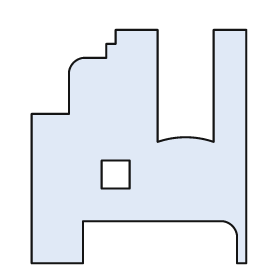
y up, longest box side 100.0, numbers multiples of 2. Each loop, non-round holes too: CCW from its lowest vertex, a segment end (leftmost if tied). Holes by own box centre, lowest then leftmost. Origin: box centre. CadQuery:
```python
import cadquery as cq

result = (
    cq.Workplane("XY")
    .moveTo(-46.0, -50.0)
    .lineTo(-24.0, -50.0)
    .lineTo(-24.0, -32.0)
    .lineTo(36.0, -32.0)
    .threePointArc((40.0, -34.0), (42.0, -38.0))
    .lineTo(42.0, -50.0)
    .lineTo(46.0, -50.0)
    .lineTo(46.0, 50.0)
    .lineTo(32.0, 50.0)
    .lineTo(32.0, 2.0)
    .threePointArc((20.0, 4.0), (8.0, 2.0))
    .lineTo(8.0, 50.0)
    .lineTo(-10.0, 50.0)
    .lineTo(-10.0, 44.0)
    .lineTo(-14.0, 44.0)
    .lineTo(-14.0, 38.0)
    .lineTo(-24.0, 38.0)
    .threePointArc((-28.0, 36.0), (-30.0, 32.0))
    .lineTo(-30.0, 14.0)
    .lineTo(-46.0, 14.0)
    .close()
    .moveTo(-16.0, -18.0)
    .lineTo(-4.0, -18.0)
    .lineTo(-4.0, -6.0)
    .lineTo(-16.0, -6.0)
    .close()
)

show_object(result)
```